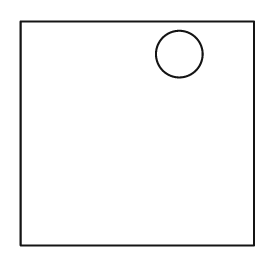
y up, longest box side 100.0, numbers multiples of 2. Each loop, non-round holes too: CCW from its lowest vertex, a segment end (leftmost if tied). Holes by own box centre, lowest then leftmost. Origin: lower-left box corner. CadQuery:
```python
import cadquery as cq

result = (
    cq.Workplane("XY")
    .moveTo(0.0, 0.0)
    .lineTo(100.0, 0.0)
    .lineTo(100.0, 96.0)
    .lineTo(0.0, 96.0)
    .close()
    .moveTo(68.0, 82.0)
    .circle(10.0)
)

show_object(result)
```